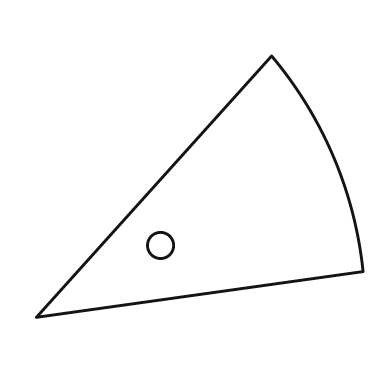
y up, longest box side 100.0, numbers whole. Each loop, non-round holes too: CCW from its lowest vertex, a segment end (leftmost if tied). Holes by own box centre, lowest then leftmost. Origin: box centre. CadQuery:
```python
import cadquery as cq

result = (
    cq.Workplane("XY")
    .moveTo(-50.0, -40.0)
    .lineTo(50.0, -26.0)
    .threePointArc((41.0, 9.0), (22.0, 40.0))
    .close()
    .moveTo(-12.0, -18.0)
    .circle(4.0)
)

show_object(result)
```